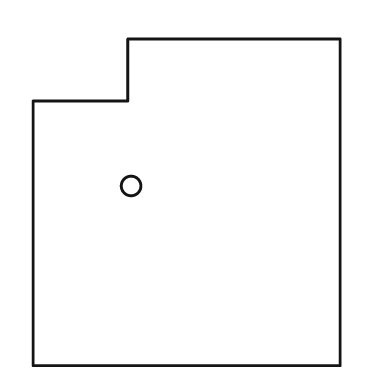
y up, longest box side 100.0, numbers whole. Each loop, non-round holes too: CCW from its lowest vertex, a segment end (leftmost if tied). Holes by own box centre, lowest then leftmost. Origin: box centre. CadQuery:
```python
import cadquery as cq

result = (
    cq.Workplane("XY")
    .moveTo(-47.0, -50.0)
    .lineTo(47.0, -50.0)
    .lineTo(47.0, 50.0)
    .lineTo(-18.0, 50.0)
    .lineTo(-18.0, 31.0)
    .lineTo(-47.0, 31.0)
    .close()
    .moveTo(-17.0, 5.0)
    .circle(3.0)
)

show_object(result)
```